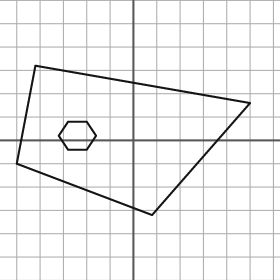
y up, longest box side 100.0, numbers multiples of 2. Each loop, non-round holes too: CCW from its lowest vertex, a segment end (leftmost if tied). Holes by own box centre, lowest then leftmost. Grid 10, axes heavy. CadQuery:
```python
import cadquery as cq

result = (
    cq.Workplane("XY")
    .moveTo(8.0, -32.0)
    .lineTo(50.0, 16.0)
    .lineTo(-42.0, 32.0)
    .lineTo(-50.0, -10.0)
    .close()
    .moveTo(-28.0, -4.0)
    .lineTo(-20.0, -4.0)
    .lineTo(-16.0, 2.0)
    .lineTo(-20.0, 8.0)
    .lineTo(-28.0, 8.0)
    .lineTo(-32.0, 2.0)
    .close()
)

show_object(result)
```